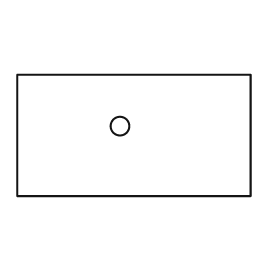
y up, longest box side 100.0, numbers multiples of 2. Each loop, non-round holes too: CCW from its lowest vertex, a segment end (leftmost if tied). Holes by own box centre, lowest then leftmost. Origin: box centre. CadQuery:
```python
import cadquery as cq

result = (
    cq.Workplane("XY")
    .moveTo(-50.0, -26.0)
    .lineTo(50.0, -26.0)
    .lineTo(50.0, 26.0)
    .lineTo(-50.0, 26.0)
    .close()
    .moveTo(-6.0, 4.0)
    .circle(4.0)
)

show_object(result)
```